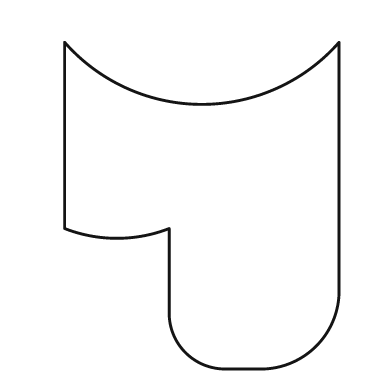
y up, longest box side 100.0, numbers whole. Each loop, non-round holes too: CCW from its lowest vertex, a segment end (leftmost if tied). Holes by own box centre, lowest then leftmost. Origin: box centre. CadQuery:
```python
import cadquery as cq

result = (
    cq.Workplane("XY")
    .moveTo(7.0, -50.0)
    .lineTo(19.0, -50.0)
    .threePointArc((35.0, -43.0), (42.0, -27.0))
    .lineTo(42.0, 50.0)
    .threePointArc((0.0, 31.0), (-42.0, 50.0))
    .lineTo(-42.0, -7.0)
    .threePointArc((-26.0, -10.0), (-10.0, -7.0))
    .lineTo(-10.0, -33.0)
    .threePointArc((-5.0, -45.0), (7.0, -50.0))
    .close()
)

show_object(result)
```